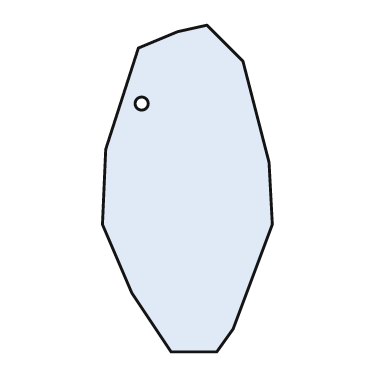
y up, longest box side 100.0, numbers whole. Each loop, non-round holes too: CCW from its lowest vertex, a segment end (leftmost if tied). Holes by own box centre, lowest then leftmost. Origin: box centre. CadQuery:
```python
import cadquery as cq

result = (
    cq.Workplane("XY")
    .moveTo(-5.0, -50.0)
    .lineTo(9.0, -50.0)
    .lineTo(14.0, -43.0)
    .lineTo(26.0, -11.0)
    .lineTo(25.0, 8.0)
    .lineTo(17.0, 39.0)
    .lineTo(6.0, 50.0)
    .lineTo(-3.0, 48.0)
    .lineTo(-15.0, 43.0)
    .lineTo(-25.0, 12.0)
    .lineTo(-26.0, -11.0)
    .lineTo(-17.0, -32.0)
    .close()
    .moveTo(-14.0, 26.0)
    .circle(2.0)
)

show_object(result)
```